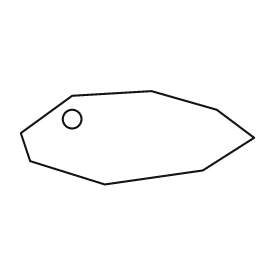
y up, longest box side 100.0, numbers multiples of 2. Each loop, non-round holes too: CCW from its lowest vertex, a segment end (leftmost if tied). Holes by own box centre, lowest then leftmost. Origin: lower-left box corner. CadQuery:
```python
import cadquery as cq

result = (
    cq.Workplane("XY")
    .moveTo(36.0, 0.0)
    .lineTo(78.0, 6.0)
    .lineTo(100.0, 20.0)
    .lineTo(84.0, 32.0)
    .lineTo(56.0, 40.0)
    .lineTo(22.0, 38.0)
    .lineTo(0.0, 22.0)
    .lineTo(4.0, 10.0)
    .close()
    .moveTo(22.0, 28.0)
    .circle(4.0)
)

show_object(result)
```